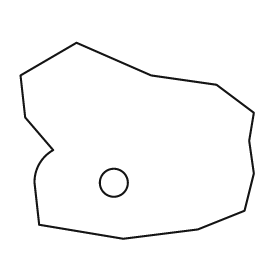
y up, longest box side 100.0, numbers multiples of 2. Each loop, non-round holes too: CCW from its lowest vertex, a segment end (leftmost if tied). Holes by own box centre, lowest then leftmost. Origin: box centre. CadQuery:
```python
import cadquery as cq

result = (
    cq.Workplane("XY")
    .moveTo(-6.0, -42.0)
    .lineTo(26.0, -38.0)
    .lineTo(46.0, -30.0)
    .lineTo(50.0, -14.0)
    .lineTo(48.0, 0.0)
    .lineTo(50.0, 12.0)
    .lineTo(34.0, 24.0)
    .lineTo(6.0, 28.0)
    .lineTo(-26.0, 42.0)
    .lineTo(-50.0, 28.0)
    .lineTo(-48.0, 10.0)
    .lineTo(-36.0, -4.0)
    .threePointArc((-42.0, -10.0), (-44.0, -18.0))
    .lineTo(-42.0, -36.0)
    .close()
    .moveTo(-10.0, -18.0)
    .circle(6.0)
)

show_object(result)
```